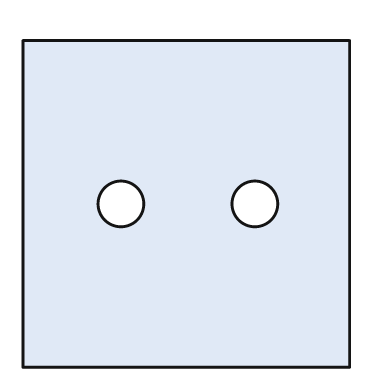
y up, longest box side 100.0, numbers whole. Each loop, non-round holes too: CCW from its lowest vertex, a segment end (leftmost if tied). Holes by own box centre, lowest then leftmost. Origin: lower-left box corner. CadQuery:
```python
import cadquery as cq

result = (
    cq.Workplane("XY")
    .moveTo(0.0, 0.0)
    .lineTo(100.0, 0.0)
    .lineTo(100.0, 100.0)
    .lineTo(0.0, 100.0)
    .close()
    .moveTo(30.0, 50.0)
    .circle(7.0)
    .moveTo(71.0, 50.0)
    .circle(7.0)
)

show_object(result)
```